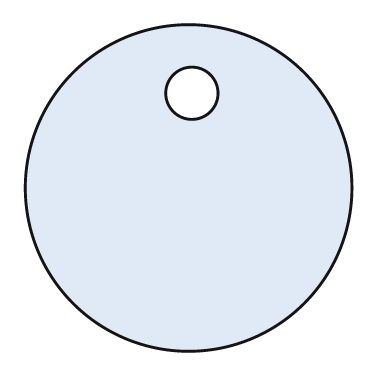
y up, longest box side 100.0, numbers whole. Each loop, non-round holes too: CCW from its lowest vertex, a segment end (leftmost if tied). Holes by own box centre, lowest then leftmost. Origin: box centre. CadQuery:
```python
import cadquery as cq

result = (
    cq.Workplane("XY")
    .moveTo(0.0, 0.0)
    .circle(50.0)
    .moveTo(1.0, 29.0)
    .circle(8.0)
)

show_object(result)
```